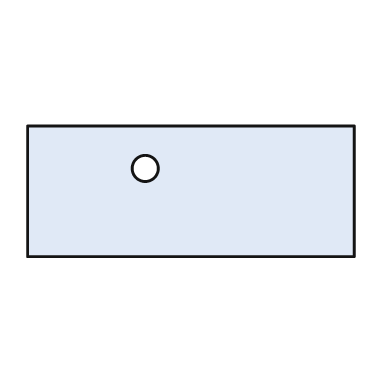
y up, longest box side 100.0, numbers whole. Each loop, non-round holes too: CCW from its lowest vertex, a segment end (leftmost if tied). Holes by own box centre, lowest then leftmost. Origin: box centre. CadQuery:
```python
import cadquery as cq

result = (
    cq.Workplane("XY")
    .moveTo(-50.0, -20.0)
    .lineTo(50.0, -20.0)
    .lineTo(50.0, 20.0)
    .lineTo(-50.0, 20.0)
    .close()
    .moveTo(-14.0, 7.0)
    .circle(4.0)
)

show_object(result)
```